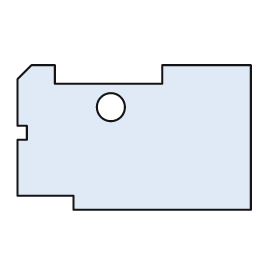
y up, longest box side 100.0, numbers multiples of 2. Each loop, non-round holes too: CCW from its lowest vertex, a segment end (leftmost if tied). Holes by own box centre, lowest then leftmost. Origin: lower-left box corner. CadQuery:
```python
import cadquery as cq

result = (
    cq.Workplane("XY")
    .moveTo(24.0, 0.0)
    .lineTo(100.0, 0.0)
    .lineTo(100.0, 62.0)
    .lineTo(62.0, 62.0)
    .lineTo(62.0, 54.0)
    .lineTo(16.0, 54.0)
    .lineTo(16.0, 62.0)
    .lineTo(6.0, 62.0)
    .lineTo(0.0, 56.0)
    .lineTo(0.0, 36.0)
    .lineTo(4.0, 36.0)
    .lineTo(4.0, 30.0)
    .lineTo(0.0, 30.0)
    .lineTo(0.0, 6.0)
    .lineTo(24.0, 6.0)
    .close()
    .moveTo(40.0, 44.0)
    .circle(6.0)
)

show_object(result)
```